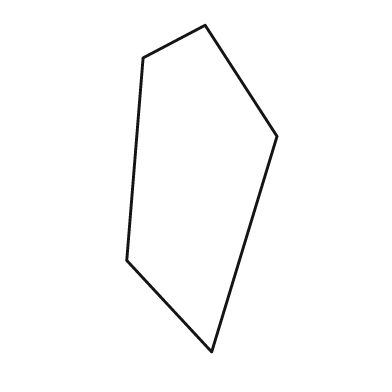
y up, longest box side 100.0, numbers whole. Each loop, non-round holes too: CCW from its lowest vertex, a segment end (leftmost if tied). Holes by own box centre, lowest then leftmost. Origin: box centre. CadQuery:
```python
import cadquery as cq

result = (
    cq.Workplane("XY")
    .moveTo(3.0, -50.0)
    .lineTo(23.0, 16.0)
    .lineTo(1.0, 50.0)
    .lineTo(-18.0, 40.0)
    .lineTo(-23.0, -22.0)
    .close()
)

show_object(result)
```